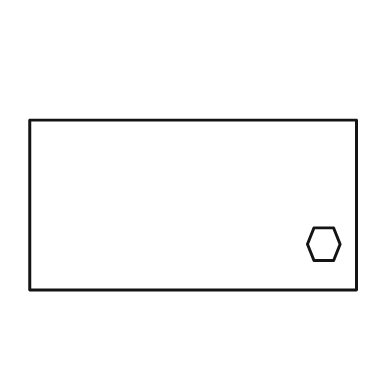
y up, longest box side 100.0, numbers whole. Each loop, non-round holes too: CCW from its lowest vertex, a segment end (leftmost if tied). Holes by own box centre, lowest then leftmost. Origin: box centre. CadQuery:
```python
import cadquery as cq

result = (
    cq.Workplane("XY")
    .moveTo(-50.0, -26.0)
    .lineTo(50.0, -26.0)
    .lineTo(50.0, 26.0)
    .lineTo(-50.0, 26.0)
    .close()
    .moveTo(37.0, -17.0)
    .lineTo(43.0, -17.0)
    .lineTo(45.0, -12.0)
    .lineTo(43.0, -7.0)
    .lineTo(37.0, -7.0)
    .lineTo(35.0, -12.0)
    .close()
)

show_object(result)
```